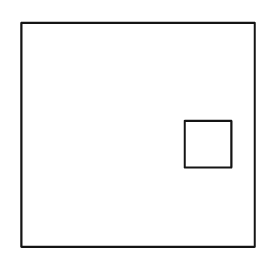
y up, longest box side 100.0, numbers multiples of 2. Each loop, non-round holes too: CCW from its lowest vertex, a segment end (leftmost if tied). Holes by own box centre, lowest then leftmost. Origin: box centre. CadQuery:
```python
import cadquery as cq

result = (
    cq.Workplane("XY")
    .moveTo(-50.0, -48.0)
    .lineTo(50.0, -48.0)
    .lineTo(50.0, 48.0)
    .lineTo(-50.0, 48.0)
    .close()
    .moveTo(20.0, -14.0)
    .lineTo(40.0, -14.0)
    .lineTo(40.0, 6.0)
    .lineTo(20.0, 6.0)
    .close()
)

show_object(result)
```